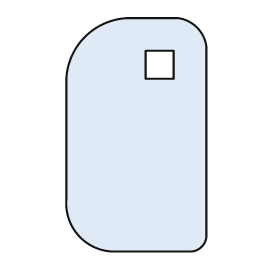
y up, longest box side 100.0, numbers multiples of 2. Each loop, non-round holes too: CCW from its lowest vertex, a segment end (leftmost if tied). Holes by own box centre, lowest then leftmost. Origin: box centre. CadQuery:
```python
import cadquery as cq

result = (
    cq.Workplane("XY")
    .moveTo(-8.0, -50.0)
    .lineTo(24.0, -50.0)
    .threePointArc((28.0, -48.0), (30.0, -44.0))
    .lineTo(30.0, 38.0)
    .threePointArc((26.0, 46.0), (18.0, 50.0))
    .lineTo(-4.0, 50.0)
    .threePointArc((-22.0, 42.0), (-30.0, 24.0))
    .lineTo(-30.0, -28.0)
    .threePointArc((-24.0, -44.0), (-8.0, -50.0))
    .close()
    .moveTo(4.0, 24.0)
    .lineTo(16.0, 24.0)
    .lineTo(16.0, 36.0)
    .lineTo(4.0, 36.0)
    .close()
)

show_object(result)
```